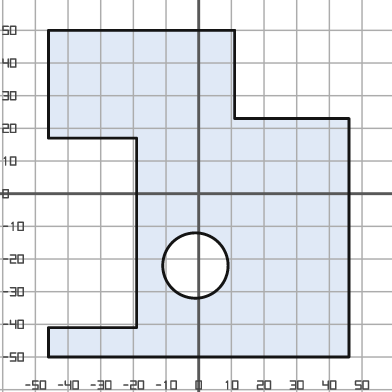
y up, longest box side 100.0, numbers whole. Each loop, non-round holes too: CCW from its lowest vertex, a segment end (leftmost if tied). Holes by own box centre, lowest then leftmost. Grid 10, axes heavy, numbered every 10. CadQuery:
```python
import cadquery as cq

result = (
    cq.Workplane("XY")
    .moveTo(-46.0, -50.0)
    .lineTo(46.0, -50.0)
    .lineTo(46.0, 23.0)
    .lineTo(11.0, 23.0)
    .lineTo(11.0, 50.0)
    .lineTo(-46.0, 50.0)
    .lineTo(-46.0, 17.0)
    .lineTo(-19.0, 17.0)
    .lineTo(-19.0, -41.0)
    .lineTo(-46.0, -41.0)
    .close()
    .moveTo(-1.0, -22.0)
    .circle(10.0)
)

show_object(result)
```